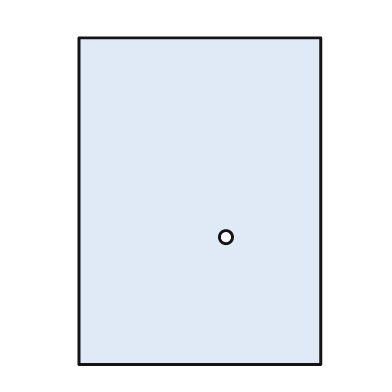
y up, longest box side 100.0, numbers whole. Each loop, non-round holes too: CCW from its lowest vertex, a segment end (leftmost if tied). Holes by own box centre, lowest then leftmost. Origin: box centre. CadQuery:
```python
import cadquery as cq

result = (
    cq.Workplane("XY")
    .moveTo(-37.0, -50.0)
    .lineTo(37.0, -50.0)
    .lineTo(37.0, 50.0)
    .lineTo(-37.0, 50.0)
    .close()
    .moveTo(8.0, -11.0)
    .circle(2.0)
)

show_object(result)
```